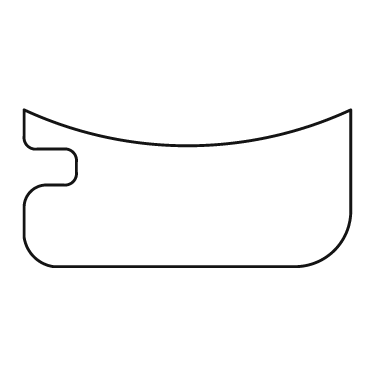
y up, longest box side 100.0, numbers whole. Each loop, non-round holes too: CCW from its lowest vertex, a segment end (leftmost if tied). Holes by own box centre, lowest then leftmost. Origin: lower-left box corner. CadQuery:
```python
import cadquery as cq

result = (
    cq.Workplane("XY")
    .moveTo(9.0, 0.0)
    .lineTo(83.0, 0.0)
    .threePointArc((95.0, 5.0), (100.0, 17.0))
    .lineTo(100.0, 48.0)
    .threePointArc((50.0, 37.0), (0.0, 48.0))
    .lineTo(0.0, 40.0)
    .threePointArc((1.0, 37.0), (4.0, 36.0))
    .lineTo(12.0, 36.0)
    .threePointArc((15.0, 35.0), (16.0, 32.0))
    .lineTo(16.0, 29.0)
    .threePointArc((15.0, 26.0), (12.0, 25.0))
    .lineTo(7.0, 25.0)
    .threePointArc((2.0, 23.0), (0.0, 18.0))
    .lineTo(0.0, 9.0)
    .threePointArc((3.0, 3.0), (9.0, 0.0))
    .close()
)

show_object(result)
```